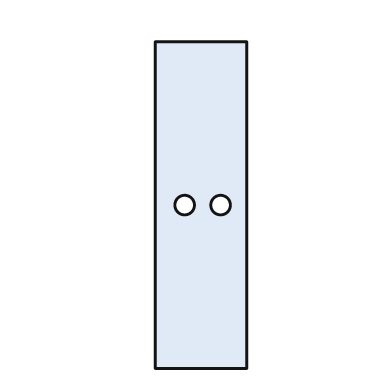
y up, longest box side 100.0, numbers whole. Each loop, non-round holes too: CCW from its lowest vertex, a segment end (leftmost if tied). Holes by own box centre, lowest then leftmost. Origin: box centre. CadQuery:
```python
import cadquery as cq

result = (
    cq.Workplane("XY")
    .moveTo(-14.0, -50.0)
    .lineTo(14.0, -50.0)
    .lineTo(14.0, 50.0)
    .lineTo(-14.0, 50.0)
    .close()
    .moveTo(-5.0, 0.0)
    .circle(3.0)
    .moveTo(6.0, 0.0)
    .circle(3.0)
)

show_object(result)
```